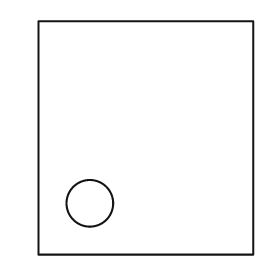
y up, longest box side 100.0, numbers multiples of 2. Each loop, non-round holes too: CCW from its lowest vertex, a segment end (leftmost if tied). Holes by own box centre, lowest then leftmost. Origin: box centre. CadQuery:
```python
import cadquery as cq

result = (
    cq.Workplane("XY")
    .moveTo(-46.0, -50.0)
    .lineTo(46.0, -50.0)
    .lineTo(46.0, 50.0)
    .lineTo(-46.0, 50.0)
    .close()
    .moveTo(-24.0, -28.0)
    .circle(10.0)
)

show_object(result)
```